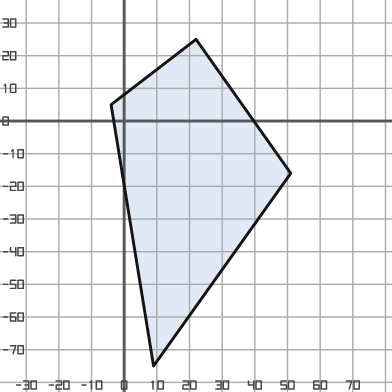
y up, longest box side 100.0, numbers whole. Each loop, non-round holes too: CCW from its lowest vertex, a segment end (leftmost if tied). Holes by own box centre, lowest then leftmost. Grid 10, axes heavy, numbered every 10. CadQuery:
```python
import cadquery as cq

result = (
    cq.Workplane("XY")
    .moveTo(9.0, -75.0)
    .lineTo(51.0, -16.0)
    .lineTo(22.0, 25.0)
    .lineTo(-4.0, 5.0)
    .close()
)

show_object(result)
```